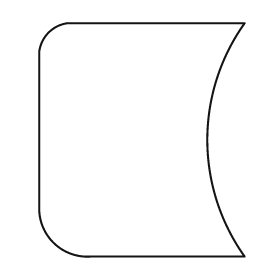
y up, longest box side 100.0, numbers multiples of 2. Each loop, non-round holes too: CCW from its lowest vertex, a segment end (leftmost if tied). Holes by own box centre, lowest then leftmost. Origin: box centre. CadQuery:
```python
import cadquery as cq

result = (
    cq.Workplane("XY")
    .moveTo(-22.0, -50.0)
    .lineTo(44.0, -50.0)
    .threePointArc((28.0, 0.0), (44.0, 50.0))
    .lineTo(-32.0, 50.0)
    .threePointArc((-40.0, 46.0), (-44.0, 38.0))
    .lineTo(-44.0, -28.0)
    .threePointArc((-38.0, -44.0), (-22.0, -50.0))
    .close()
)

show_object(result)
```